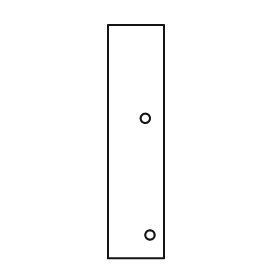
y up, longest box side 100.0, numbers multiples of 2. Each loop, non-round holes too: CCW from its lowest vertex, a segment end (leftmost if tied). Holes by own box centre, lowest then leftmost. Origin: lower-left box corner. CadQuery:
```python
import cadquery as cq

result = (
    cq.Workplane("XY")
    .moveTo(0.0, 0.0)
    .lineTo(24.0, 0.0)
    .lineTo(24.0, 100.0)
    .lineTo(0.0, 100.0)
    .close()
    .moveTo(18.0, 10.0)
    .circle(2.0)
    .moveTo(16.0, 60.0)
    .circle(2.0)
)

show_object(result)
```